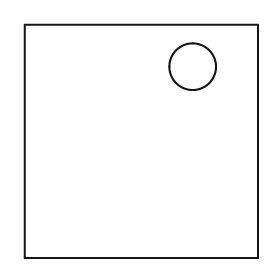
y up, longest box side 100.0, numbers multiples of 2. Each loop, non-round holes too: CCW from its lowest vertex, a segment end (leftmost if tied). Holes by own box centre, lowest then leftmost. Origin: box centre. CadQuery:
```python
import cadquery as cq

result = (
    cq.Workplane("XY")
    .moveTo(-50.0, -50.0)
    .lineTo(50.0, -50.0)
    .lineTo(50.0, 50.0)
    .lineTo(-50.0, 50.0)
    .close()
    .moveTo(22.0, 32.0)
    .circle(10.0)
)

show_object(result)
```